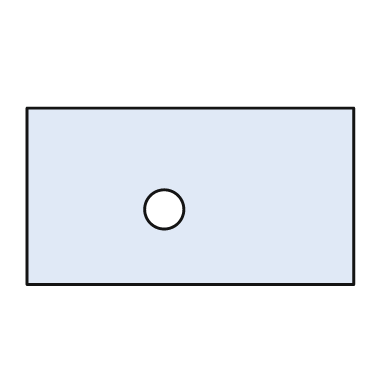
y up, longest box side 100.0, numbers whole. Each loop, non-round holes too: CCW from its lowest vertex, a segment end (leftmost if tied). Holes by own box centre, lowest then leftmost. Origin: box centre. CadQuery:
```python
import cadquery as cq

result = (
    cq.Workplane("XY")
    .moveTo(-50.0, -27.0)
    .lineTo(50.0, -27.0)
    .lineTo(50.0, 27.0)
    .lineTo(-50.0, 27.0)
    .close()
    .moveTo(-8.0, -4.0)
    .circle(6.0)
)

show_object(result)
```